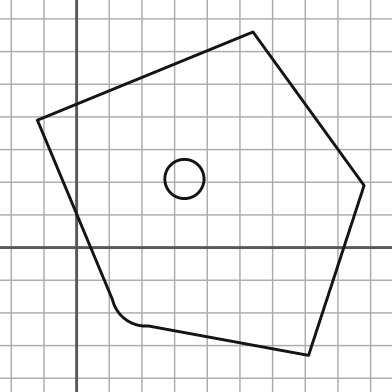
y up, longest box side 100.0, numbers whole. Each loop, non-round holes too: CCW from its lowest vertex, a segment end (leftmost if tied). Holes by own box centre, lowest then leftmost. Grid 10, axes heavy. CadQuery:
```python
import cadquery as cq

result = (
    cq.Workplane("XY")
    .moveTo(71.0, -33.0)
    .lineTo(88.0, 19.0)
    .lineTo(54.0, 66.0)
    .lineTo(-12.0, 39.0)
    .lineTo(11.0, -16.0)
    .threePointArc((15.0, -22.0), (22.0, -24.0))
    .close()
    .moveTo(33.0, 21.0)
    .circle(6.0)
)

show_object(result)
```